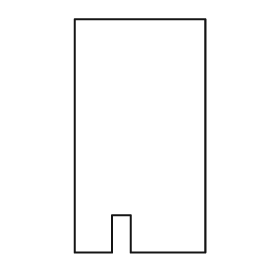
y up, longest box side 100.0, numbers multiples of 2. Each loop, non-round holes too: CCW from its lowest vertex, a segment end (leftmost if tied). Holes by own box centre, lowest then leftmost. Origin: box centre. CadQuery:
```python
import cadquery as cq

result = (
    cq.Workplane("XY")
    .moveTo(-28.0, -50.0)
    .lineTo(-12.0, -50.0)
    .lineTo(-12.0, -34.0)
    .lineTo(-4.0, -34.0)
    .lineTo(-4.0, -50.0)
    .lineTo(28.0, -50.0)
    .lineTo(28.0, 50.0)
    .lineTo(-28.0, 50.0)
    .close()
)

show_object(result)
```